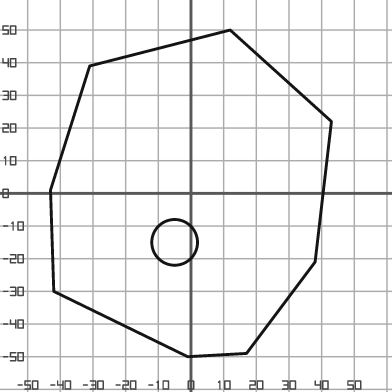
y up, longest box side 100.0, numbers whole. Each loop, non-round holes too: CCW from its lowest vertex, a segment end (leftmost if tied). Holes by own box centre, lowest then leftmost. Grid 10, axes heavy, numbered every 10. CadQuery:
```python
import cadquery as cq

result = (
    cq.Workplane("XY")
    .moveTo(-1.0, -50.0)
    .lineTo(17.0, -49.0)
    .lineTo(38.0, -21.0)
    .lineTo(43.0, 22.0)
    .lineTo(12.0, 50.0)
    .lineTo(-31.0, 39.0)
    .lineTo(-43.0, 1.0)
    .lineTo(-42.0, -30.0)
    .close()
    .moveTo(-5.0, -15.0)
    .circle(7.0)
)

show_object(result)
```